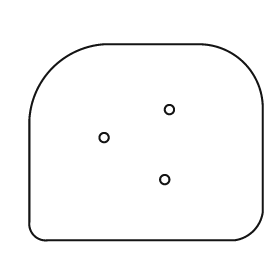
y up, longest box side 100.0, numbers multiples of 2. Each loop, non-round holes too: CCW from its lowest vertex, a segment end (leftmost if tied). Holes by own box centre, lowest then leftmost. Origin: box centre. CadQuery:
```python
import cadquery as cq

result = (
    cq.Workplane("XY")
    .moveTo(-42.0, -42.0)
    .lineTo(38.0, -42.0)
    .threePointArc((46.0, -38.0), (50.0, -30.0))
    .lineTo(50.0, 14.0)
    .threePointArc((42.0, 34.0), (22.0, 42.0))
    .lineTo(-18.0, 42.0)
    .threePointArc((-40.0, 32.0), (-50.0, 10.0))
    .lineTo(-50.0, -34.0)
    .threePointArc((-48.0, -40.0), (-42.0, -42.0))
    .close()
    .moveTo(8.0, -16.0)
    .circle(2.0)
    .moveTo(-18.0, 2.0)
    .circle(2.0)
    .moveTo(10.0, 14.0)
    .circle(2.0)
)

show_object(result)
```